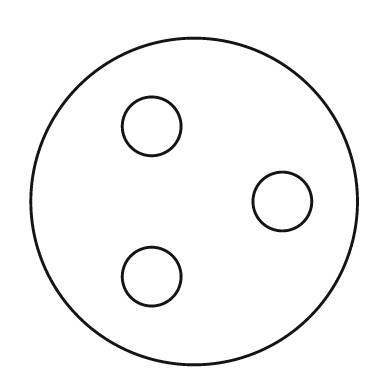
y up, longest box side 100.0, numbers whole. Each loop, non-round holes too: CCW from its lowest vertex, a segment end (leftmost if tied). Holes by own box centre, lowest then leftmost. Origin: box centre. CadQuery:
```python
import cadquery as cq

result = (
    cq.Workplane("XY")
    .moveTo(0.0, 0.0)
    .circle(50.0)
    .moveTo(-13.0, -23.0)
    .circle(9.0)
    .moveTo(27.0, 0.0)
    .circle(9.0)
    .moveTo(-13.0, 23.0)
    .circle(9.0)
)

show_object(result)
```